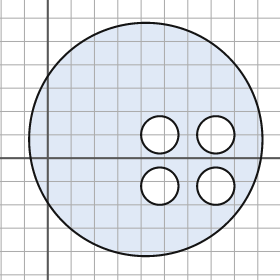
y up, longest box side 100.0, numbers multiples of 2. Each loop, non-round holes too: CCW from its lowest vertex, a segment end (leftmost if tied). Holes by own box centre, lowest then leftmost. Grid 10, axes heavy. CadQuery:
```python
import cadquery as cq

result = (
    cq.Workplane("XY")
    .moveTo(42.0, 8.0)
    .circle(50.0)
    .moveTo(48.0, -12.0)
    .circle(8.0)
    .moveTo(72.0, -12.0)
    .circle(8.0)
    .moveTo(48.0, 10.0)
    .circle(8.0)
    .moveTo(72.0, 10.0)
    .circle(8.0)
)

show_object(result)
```